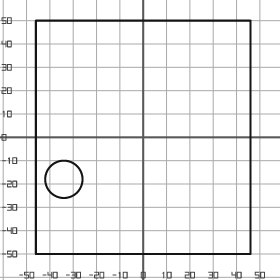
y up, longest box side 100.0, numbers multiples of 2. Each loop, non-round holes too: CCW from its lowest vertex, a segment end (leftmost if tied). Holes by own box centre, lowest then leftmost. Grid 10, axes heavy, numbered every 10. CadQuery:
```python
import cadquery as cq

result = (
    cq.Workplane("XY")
    .moveTo(-46.0, -50.0)
    .lineTo(46.0, -50.0)
    .lineTo(46.0, 50.0)
    .lineTo(-46.0, 50.0)
    .close()
    .moveTo(-34.0, -18.0)
    .circle(8.0)
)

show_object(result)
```